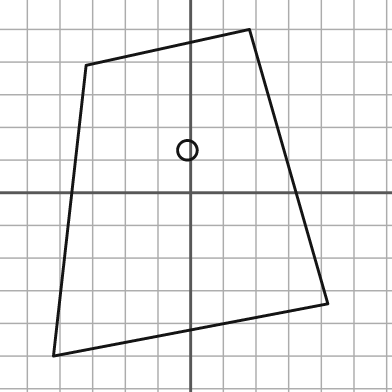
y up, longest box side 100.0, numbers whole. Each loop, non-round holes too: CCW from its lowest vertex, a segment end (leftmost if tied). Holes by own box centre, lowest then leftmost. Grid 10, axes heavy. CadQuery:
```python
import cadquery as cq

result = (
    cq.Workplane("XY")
    .moveTo(-42.0, -50.0)
    .lineTo(42.0, -34.0)
    .lineTo(18.0, 50.0)
    .lineTo(-32.0, 39.0)
    .close()
    .moveTo(-1.0, 13.0)
    .circle(3.0)
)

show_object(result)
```